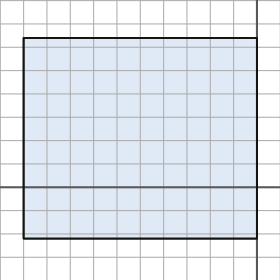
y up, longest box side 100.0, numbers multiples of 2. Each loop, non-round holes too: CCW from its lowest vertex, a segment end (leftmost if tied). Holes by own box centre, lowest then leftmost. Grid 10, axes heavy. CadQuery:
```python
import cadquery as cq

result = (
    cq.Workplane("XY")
    .moveTo(-100.0, -22.0)
    .lineTo(0.0, -22.0)
    .lineTo(0.0, 64.0)
    .lineTo(-100.0, 64.0)
    .close()
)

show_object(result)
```